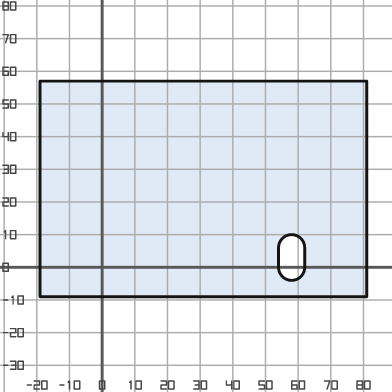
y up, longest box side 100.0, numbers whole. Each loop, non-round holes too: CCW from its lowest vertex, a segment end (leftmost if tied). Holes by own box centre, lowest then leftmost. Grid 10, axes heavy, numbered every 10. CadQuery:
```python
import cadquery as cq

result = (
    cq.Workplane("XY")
    .moveTo(-19.0, -9.0)
    .lineTo(81.0, -9.0)
    .lineTo(81.0, 57.0)
    .lineTo(-19.0, 57.0)
    .close()
    .moveTo(54.0, 0.0)
    .threePointArc((58.0, -4.0), (62.0, 0.0))
    .lineTo(62.0, 6.0)
    .threePointArc((58.0, 10.0), (54.0, 6.0))
    .close()
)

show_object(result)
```